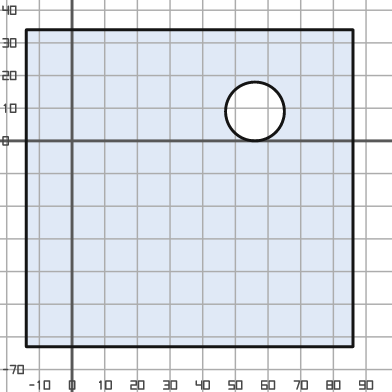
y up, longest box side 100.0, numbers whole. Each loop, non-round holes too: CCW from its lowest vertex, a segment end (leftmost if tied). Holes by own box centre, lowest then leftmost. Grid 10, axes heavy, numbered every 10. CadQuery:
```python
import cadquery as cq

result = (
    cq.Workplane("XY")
    .moveTo(-14.0, -63.0)
    .lineTo(86.0, -63.0)
    .lineTo(86.0, 34.0)
    .lineTo(-14.0, 34.0)
    .close()
    .moveTo(56.0, 9.0)
    .circle(9.0)
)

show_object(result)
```